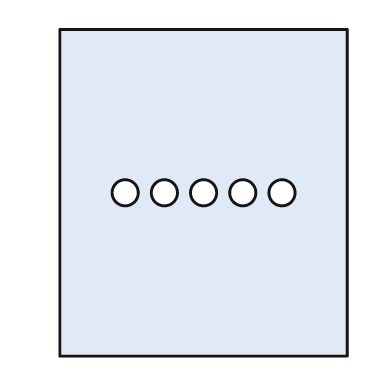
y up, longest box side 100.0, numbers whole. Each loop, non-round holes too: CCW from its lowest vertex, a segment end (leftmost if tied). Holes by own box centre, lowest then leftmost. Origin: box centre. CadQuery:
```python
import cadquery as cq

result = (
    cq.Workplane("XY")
    .moveTo(-44.0, -50.0)
    .lineTo(44.0, -50.0)
    .lineTo(44.0, 50.0)
    .lineTo(-44.0, 50.0)
    .close()
    .moveTo(-24.0, 0.0)
    .circle(4.0)
    .moveTo(-12.0, 0.0)
    .circle(4.0)
    .moveTo(0.0, 0.0)
    .circle(4.0)
    .moveTo(12.0, 0.0)
    .circle(4.0)
    .moveTo(24.0, 0.0)
    .circle(4.0)
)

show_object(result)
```